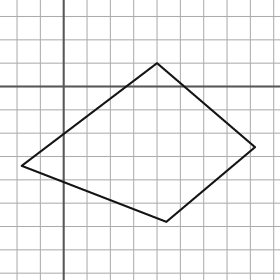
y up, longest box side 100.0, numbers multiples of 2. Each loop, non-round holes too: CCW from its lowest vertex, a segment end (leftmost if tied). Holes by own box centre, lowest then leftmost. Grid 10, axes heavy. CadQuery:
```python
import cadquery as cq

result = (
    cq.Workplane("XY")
    .moveTo(44.0, -58.0)
    .lineTo(82.0, -26.0)
    .lineTo(40.0, 10.0)
    .lineTo(-18.0, -34.0)
    .close()
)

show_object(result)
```